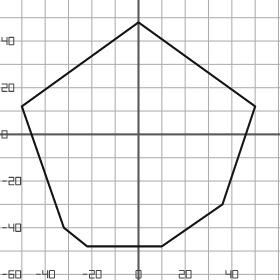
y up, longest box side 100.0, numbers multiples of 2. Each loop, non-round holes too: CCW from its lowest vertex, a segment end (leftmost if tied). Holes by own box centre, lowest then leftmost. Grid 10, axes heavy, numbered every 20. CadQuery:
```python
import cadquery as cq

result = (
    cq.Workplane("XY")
    .moveTo(-22.0, -48.0)
    .lineTo(10.0, -48.0)
    .lineTo(36.0, -30.0)
    .lineTo(50.0, 12.0)
    .lineTo(0.0, 48.0)
    .lineTo(-50.0, 12.0)
    .lineTo(-32.0, -40.0)
    .close()
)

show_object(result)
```